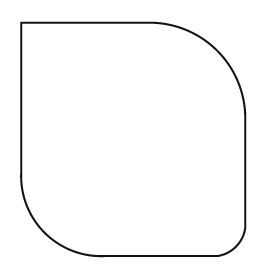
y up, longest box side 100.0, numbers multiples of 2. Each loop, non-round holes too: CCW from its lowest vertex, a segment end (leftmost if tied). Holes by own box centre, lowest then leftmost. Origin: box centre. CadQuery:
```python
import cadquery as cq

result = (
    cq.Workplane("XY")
    .moveTo(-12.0, -50.0)
    .lineTo(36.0, -50.0)
    .threePointArc((44.0, -46.0), (48.0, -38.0))
    .lineTo(48.0, 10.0)
    .threePointArc((36.0, 38.0), (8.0, 50.0))
    .lineTo(-48.0, 50.0)
    .lineTo(-48.0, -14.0)
    .threePointArc((-38.0, -40.0), (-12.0, -50.0))
    .close()
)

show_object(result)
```